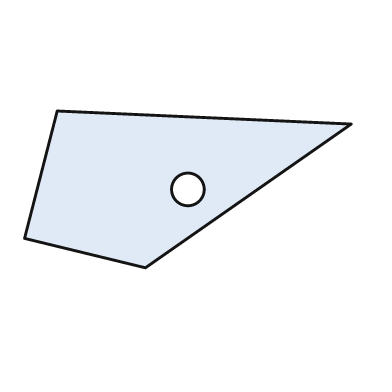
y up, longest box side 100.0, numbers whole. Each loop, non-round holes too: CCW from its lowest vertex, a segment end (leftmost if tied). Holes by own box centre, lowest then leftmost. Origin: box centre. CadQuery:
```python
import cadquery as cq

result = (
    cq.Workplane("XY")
    .moveTo(-13.0, -24.0)
    .lineTo(50.0, 20.0)
    .lineTo(-40.0, 24.0)
    .lineTo(-50.0, -15.0)
    .close()
    .moveTo(0.0, 0.0)
    .circle(5.0)
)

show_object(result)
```